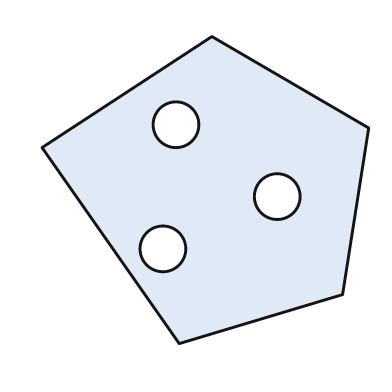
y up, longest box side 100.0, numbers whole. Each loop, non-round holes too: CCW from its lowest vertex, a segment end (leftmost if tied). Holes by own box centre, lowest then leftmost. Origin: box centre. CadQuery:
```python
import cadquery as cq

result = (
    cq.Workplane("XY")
    .moveTo(-8.0, -47.0)
    .lineTo(42.0, -32.0)
    .lineTo(50.0, 19.0)
    .lineTo(2.0, 47.0)
    .lineTo(-50.0, 13.0)
    .close()
    .moveTo(-13.0, -18.0)
    .circle(7.0)
    .moveTo(22.0, -2.0)
    .circle(7.0)
    .moveTo(-9.0, 20.0)
    .circle(7.0)
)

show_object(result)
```